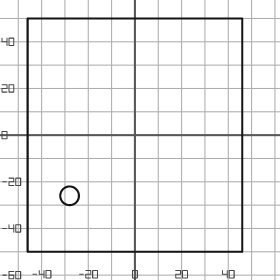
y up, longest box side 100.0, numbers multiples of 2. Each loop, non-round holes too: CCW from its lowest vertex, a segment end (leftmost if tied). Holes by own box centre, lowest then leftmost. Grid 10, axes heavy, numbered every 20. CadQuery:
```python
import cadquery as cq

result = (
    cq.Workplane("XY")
    .moveTo(-46.0, -50.0)
    .lineTo(46.0, -50.0)
    .lineTo(46.0, 50.0)
    .lineTo(-46.0, 50.0)
    .close()
    .moveTo(-28.0, -26.0)
    .circle(4.0)
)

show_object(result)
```